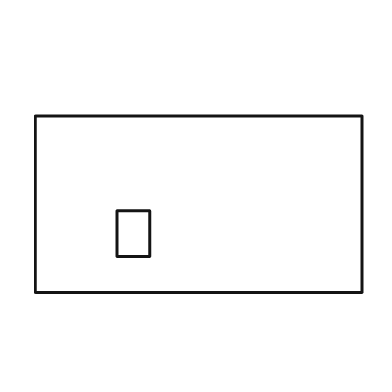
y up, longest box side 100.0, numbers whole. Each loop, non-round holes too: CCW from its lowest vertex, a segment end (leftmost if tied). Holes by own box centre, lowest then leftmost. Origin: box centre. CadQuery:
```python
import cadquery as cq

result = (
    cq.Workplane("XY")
    .moveTo(-50.0, -27.0)
    .lineTo(50.0, -27.0)
    .lineTo(50.0, 27.0)
    .lineTo(-50.0, 27.0)
    .close()
    .moveTo(-25.0, -16.0)
    .lineTo(-15.0, -16.0)
    .lineTo(-15.0, -2.0)
    .lineTo(-25.0, -2.0)
    .close()
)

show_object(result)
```